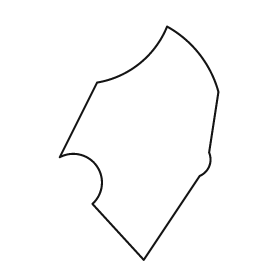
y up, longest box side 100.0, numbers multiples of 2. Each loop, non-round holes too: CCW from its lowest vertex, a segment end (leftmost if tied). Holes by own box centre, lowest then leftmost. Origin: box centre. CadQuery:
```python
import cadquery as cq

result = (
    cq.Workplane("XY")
    .moveTo(2.0, -50.0)
    .lineTo(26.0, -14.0)
    .threePointArc((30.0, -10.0), (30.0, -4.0))
    .lineTo(34.0, 22.0)
    .threePointArc((26.0, 38.0), (12.0, 50.0))
    .threePointArc((0.0, 34.0), (-18.0, 26.0))
    .lineTo(-34.0, -6.0)
    .threePointArc((-18.0, -10.0), (-20.0, -26.0))
    .close()
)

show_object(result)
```